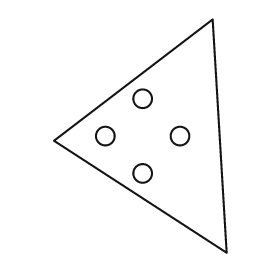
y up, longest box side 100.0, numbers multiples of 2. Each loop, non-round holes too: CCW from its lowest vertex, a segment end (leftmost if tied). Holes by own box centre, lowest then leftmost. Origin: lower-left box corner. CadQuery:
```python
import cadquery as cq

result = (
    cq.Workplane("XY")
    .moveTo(74.0, 0.0)
    .lineTo(68.0, 100.0)
    .lineTo(0.0, 48.0)
    .close()
    .moveTo(38.0, 34.0)
    .circle(4.0)
    .moveTo(22.0, 50.0)
    .circle(4.0)
    .moveTo(54.0, 50.0)
    .circle(4.0)
    .moveTo(38.0, 66.0)
    .circle(4.0)
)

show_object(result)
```